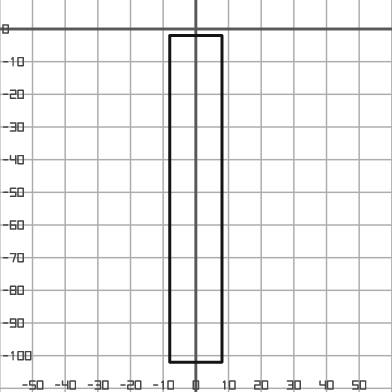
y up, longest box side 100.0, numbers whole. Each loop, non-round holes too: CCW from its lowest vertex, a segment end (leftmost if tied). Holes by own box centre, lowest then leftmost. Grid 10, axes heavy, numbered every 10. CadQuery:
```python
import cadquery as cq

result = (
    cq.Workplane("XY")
    .moveTo(-8.0, -102.0)
    .lineTo(8.0, -102.0)
    .lineTo(8.0, -2.0)
    .lineTo(-8.0, -2.0)
    .close()
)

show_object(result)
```